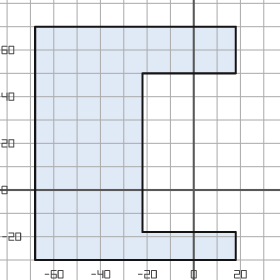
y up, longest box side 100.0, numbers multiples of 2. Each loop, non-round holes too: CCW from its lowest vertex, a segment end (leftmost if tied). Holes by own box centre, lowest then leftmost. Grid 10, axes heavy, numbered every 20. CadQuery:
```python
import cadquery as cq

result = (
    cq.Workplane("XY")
    .moveTo(-68.0, -30.0)
    .lineTo(18.0, -30.0)
    .lineTo(18.0, -18.0)
    .lineTo(-22.0, -18.0)
    .lineTo(-22.0, 50.0)
    .lineTo(18.0, 50.0)
    .lineTo(18.0, 70.0)
    .lineTo(-68.0, 70.0)
    .close()
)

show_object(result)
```